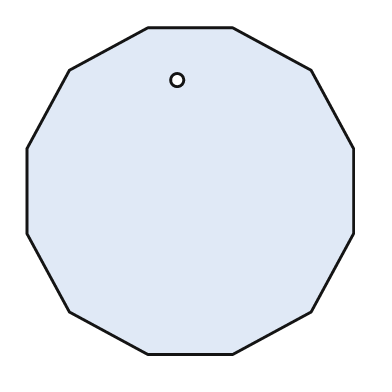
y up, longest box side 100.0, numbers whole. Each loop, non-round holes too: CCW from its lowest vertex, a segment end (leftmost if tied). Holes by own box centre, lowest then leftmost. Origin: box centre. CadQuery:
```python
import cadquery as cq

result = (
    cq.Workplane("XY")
    .moveTo(-13.0, -50.0)
    .lineTo(13.0, -50.0)
    .lineTo(37.0, -37.0)
    .lineTo(50.0, -13.0)
    .lineTo(50.0, 13.0)
    .lineTo(37.0, 37.0)
    .lineTo(13.0, 50.0)
    .lineTo(-13.0, 50.0)
    .lineTo(-37.0, 37.0)
    .lineTo(-50.0, 13.0)
    .lineTo(-50.0, -13.0)
    .lineTo(-37.0, -37.0)
    .close()
    .moveTo(-4.0, 34.0)
    .circle(2.0)
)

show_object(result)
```